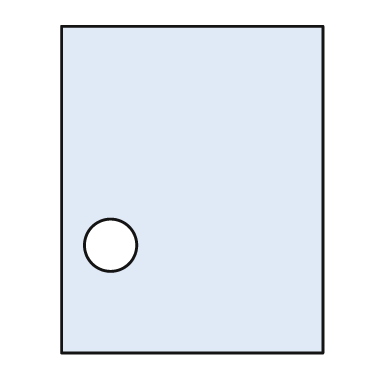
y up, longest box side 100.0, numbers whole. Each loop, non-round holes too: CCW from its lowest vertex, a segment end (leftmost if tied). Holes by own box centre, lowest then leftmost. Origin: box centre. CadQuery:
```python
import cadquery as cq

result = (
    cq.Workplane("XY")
    .moveTo(-40.0, -50.0)
    .lineTo(40.0, -50.0)
    .lineTo(40.0, 50.0)
    .lineTo(-40.0, 50.0)
    .close()
    .moveTo(-25.0, -17.0)
    .circle(8.0)
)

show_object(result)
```